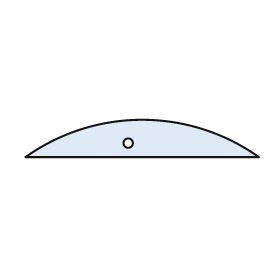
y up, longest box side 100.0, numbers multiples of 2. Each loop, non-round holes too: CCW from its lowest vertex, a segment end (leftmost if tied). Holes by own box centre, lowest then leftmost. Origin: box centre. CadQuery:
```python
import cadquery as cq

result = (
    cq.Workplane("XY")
    .moveTo(-50.0, -8.0)
    .lineTo(50.0, -8.0)
    .threePointArc((0.0, 8.0), (-50.0, -8.0))
    .close()
    .moveTo(-6.0, -2.0)
    .circle(2.0)
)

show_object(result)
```